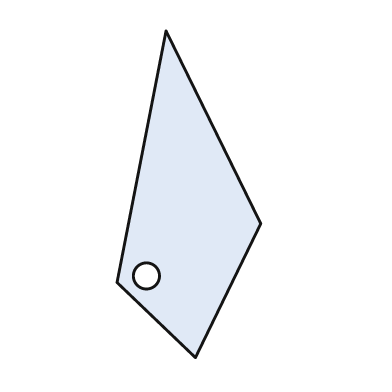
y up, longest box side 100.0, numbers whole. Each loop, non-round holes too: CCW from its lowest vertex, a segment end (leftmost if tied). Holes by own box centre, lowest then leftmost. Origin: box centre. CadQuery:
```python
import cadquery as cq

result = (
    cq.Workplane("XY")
    .moveTo(2.0, -50.0)
    .lineTo(22.0, -9.0)
    .lineTo(-7.0, 50.0)
    .lineTo(-22.0, -27.0)
    .close()
    .moveTo(-13.0, -25.0)
    .circle(4.0)
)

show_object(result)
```